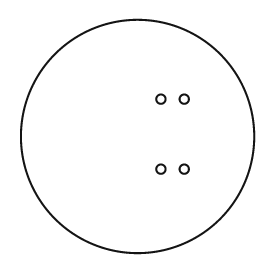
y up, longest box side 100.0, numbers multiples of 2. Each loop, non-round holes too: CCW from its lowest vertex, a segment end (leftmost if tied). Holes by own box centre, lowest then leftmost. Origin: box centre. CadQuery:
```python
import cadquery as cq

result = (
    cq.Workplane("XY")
    .moveTo(0.0, 0.0)
    .circle(50.0)
    .moveTo(10.0, -14.0)
    .circle(2.0)
    .moveTo(20.0, -14.0)
    .circle(2.0)
    .moveTo(10.0, 16.0)
    .circle(2.0)
    .moveTo(20.0, 16.0)
    .circle(2.0)
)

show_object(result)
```